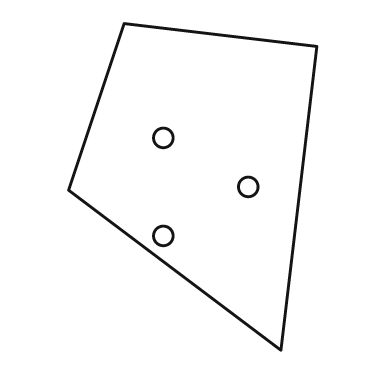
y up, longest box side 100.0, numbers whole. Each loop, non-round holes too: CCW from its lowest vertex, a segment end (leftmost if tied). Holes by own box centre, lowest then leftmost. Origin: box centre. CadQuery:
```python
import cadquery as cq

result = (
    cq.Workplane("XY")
    .moveTo(27.0, -50.0)
    .lineTo(38.0, 43.0)
    .lineTo(-21.0, 50.0)
    .lineTo(-38.0, -1.0)
    .close()
    .moveTo(-9.0, -15.0)
    .circle(3.0)
    .moveTo(17.0, 0.0)
    .circle(3.0)
    .moveTo(-9.0, 15.0)
    .circle(3.0)
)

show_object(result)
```